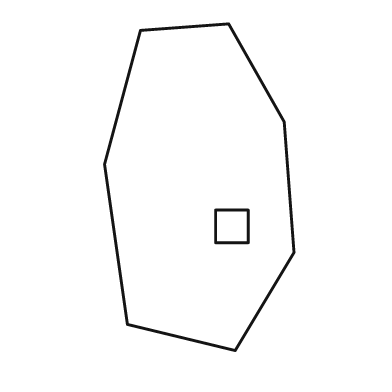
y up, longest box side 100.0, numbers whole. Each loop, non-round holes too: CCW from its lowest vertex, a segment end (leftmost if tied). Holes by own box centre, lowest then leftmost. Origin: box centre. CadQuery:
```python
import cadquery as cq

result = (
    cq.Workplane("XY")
    .moveTo(11.0, -50.0)
    .lineTo(29.0, -20.0)
    .lineTo(26.0, 20.0)
    .lineTo(9.0, 50.0)
    .lineTo(-18.0, 48.0)
    .lineTo(-29.0, 7.0)
    .lineTo(-22.0, -42.0)
    .close()
    .moveTo(5.0, -17.0)
    .lineTo(15.0, -17.0)
    .lineTo(15.0, -7.0)
    .lineTo(5.0, -7.0)
    .close()
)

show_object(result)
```